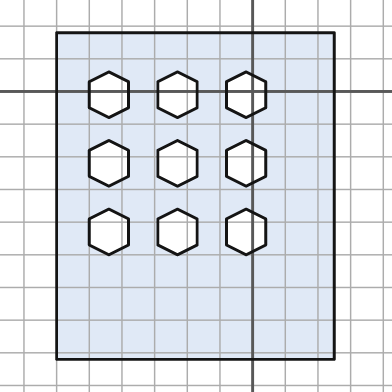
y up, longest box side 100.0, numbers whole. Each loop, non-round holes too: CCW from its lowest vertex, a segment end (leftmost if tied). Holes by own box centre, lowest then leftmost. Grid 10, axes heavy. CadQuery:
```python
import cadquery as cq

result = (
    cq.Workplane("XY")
    .moveTo(-60.0, -82.0)
    .lineTo(25.0, -82.0)
    .lineTo(25.0, 18.0)
    .lineTo(-60.0, 18.0)
    .close()
    .moveTo(-44.0, -50.0)
    .lineTo(-38.0, -47.0)
    .lineTo(-38.0, -39.0)
    .lineTo(-44.0, -36.0)
    .lineTo(-50.0, -39.0)
    .lineTo(-50.0, -47.0)
    .close()
    .moveTo(-23.0, -50.0)
    .lineTo(-17.0, -47.0)
    .lineTo(-17.0, -39.0)
    .lineTo(-23.0, -36.0)
    .lineTo(-29.0, -39.0)
    .lineTo(-29.0, -47.0)
    .close()
    .moveTo(-2.0, -50.0)
    .lineTo(4.0, -47.0)
    .lineTo(4.0, -39.0)
    .lineTo(-2.0, -36.0)
    .lineTo(-8.0, -39.0)
    .lineTo(-8.0, -47.0)
    .close()
    .moveTo(-44.0, -29.0)
    .lineTo(-38.0, -26.0)
    .lineTo(-38.0, -18.0)
    .lineTo(-44.0, -15.0)
    .lineTo(-50.0, -18.0)
    .lineTo(-50.0, -26.0)
    .close()
    .moveTo(-23.0, -29.0)
    .lineTo(-17.0, -26.0)
    .lineTo(-17.0, -18.0)
    .lineTo(-23.0, -15.0)
    .lineTo(-29.0, -18.0)
    .lineTo(-29.0, -26.0)
    .close()
    .moveTo(-2.0, -29.0)
    .lineTo(4.0, -26.0)
    .lineTo(4.0, -18.0)
    .lineTo(-2.0, -15.0)
    .lineTo(-8.0, -18.0)
    .lineTo(-8.0, -26.0)
    .close()
    .moveTo(-44.0, -8.0)
    .lineTo(-38.0, -5.0)
    .lineTo(-38.0, 3.0)
    .lineTo(-44.0, 6.0)
    .lineTo(-50.0, 3.0)
    .lineTo(-50.0, -5.0)
    .close()
    .moveTo(-23.0, -8.0)
    .lineTo(-17.0, -5.0)
    .lineTo(-17.0, 3.0)
    .lineTo(-23.0, 6.0)
    .lineTo(-29.0, 3.0)
    .lineTo(-29.0, -5.0)
    .close()
    .moveTo(-2.0, -8.0)
    .lineTo(4.0, -5.0)
    .lineTo(4.0, 3.0)
    .lineTo(-2.0, 6.0)
    .lineTo(-8.0, 3.0)
    .lineTo(-8.0, -5.0)
    .close()
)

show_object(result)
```